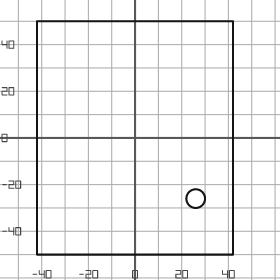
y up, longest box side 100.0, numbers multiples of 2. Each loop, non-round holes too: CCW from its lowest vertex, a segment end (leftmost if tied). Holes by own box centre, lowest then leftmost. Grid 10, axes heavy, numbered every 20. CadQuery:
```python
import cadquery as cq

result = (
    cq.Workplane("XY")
    .moveTo(-42.0, -50.0)
    .lineTo(42.0, -50.0)
    .lineTo(42.0, 50.0)
    .lineTo(-42.0, 50.0)
    .close()
    .moveTo(26.0, -26.0)
    .circle(4.0)
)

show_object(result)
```